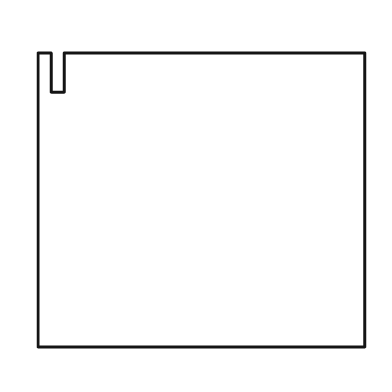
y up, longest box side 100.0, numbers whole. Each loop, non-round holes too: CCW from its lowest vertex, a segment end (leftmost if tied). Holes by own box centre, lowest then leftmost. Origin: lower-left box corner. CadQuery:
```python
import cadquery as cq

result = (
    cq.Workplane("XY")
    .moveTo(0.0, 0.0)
    .lineTo(100.0, 0.0)
    .lineTo(100.0, 90.0)
    .lineTo(8.0, 90.0)
    .lineTo(8.0, 78.0)
    .lineTo(4.0, 78.0)
    .lineTo(4.0, 90.0)
    .lineTo(0.0, 90.0)
    .close()
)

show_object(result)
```